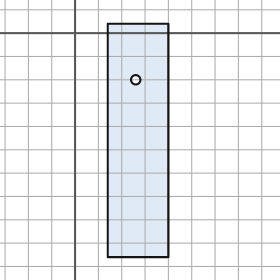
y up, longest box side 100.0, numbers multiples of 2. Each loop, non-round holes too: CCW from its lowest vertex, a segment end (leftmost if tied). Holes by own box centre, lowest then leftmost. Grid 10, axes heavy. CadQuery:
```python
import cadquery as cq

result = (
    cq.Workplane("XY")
    .moveTo(14.0, -96.0)
    .lineTo(40.0, -96.0)
    .lineTo(40.0, 4.0)
    .lineTo(14.0, 4.0)
    .close()
    .moveTo(26.0, -20.0)
    .circle(2.0)
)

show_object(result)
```